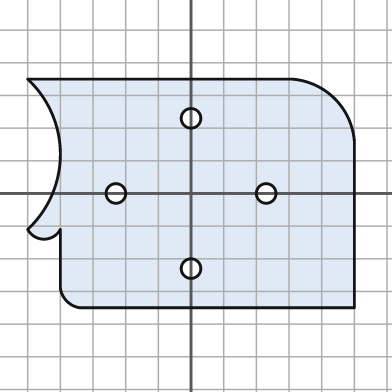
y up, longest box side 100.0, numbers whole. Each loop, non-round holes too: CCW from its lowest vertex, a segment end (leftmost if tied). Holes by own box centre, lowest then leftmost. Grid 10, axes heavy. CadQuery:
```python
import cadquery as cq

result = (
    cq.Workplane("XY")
    .moveTo(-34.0, -35.0)
    .lineTo(50.0, -35.0)
    .lineTo(50.0, 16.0)
    .threePointArc((44.0, 29.0), (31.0, 35.0))
    .lineTo(-50.0, 35.0)
    .threePointArc((-40.0, 12.0), (-50.0, -11.0))
    .threePointArc((-45.0, -14.0), (-40.0, -11.0))
    .lineTo(-40.0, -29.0)
    .threePointArc((-38.0, -33.0), (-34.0, -35.0))
    .close()
    .moveTo(0.0, -23.0)
    .circle(3.0)
    .moveTo(-23.0, 0.0)
    .circle(3.0)
    .moveTo(23.0, 0.0)
    .circle(3.0)
    .moveTo(0.0, 23.0)
    .circle(3.0)
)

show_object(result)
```